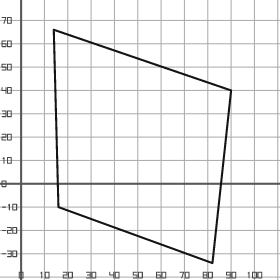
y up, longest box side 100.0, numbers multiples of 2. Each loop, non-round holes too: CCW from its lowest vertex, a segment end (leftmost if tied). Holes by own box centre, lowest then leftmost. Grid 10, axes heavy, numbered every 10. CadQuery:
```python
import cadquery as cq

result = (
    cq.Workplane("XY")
    .moveTo(82.0, -34.0)
    .lineTo(90.0, 40.0)
    .lineTo(14.0, 66.0)
    .lineTo(16.0, -10.0)
    .close()
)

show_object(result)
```